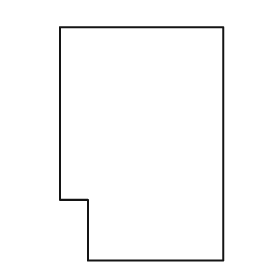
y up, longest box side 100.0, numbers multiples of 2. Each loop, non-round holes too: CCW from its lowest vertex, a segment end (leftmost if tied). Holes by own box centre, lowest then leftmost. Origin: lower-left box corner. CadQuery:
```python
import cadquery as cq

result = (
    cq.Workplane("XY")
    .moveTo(12.0, 0.0)
    .lineTo(70.0, 0.0)
    .lineTo(70.0, 100.0)
    .lineTo(0.0, 100.0)
    .lineTo(0.0, 26.0)
    .lineTo(12.0, 26.0)
    .close()
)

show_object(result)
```